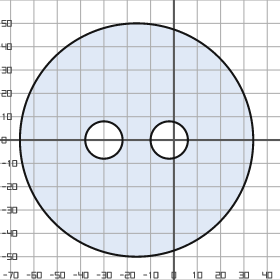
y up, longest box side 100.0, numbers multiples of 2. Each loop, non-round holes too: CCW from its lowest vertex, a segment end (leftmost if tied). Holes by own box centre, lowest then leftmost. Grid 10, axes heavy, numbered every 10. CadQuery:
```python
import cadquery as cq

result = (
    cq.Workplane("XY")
    .moveTo(-16.0, 0.0)
    .circle(50.0)
    .moveTo(-30.0, 0.0)
    .circle(8.0)
    .moveTo(-2.0, 0.0)
    .circle(8.0)
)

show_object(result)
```